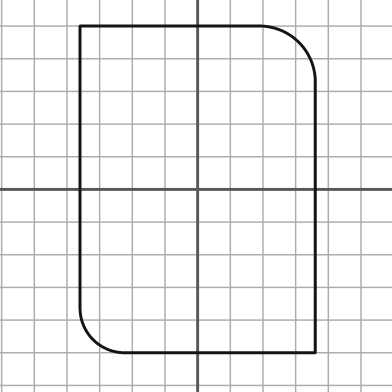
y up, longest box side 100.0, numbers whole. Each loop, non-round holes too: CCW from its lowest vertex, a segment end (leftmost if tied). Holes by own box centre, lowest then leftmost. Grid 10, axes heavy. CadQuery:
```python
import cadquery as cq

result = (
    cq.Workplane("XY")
    .moveTo(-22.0, -50.0)
    .lineTo(36.0, -50.0)
    .lineTo(36.0, 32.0)
    .threePointArc((31.0, 45.0), (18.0, 50.0))
    .lineTo(-36.0, 50.0)
    .lineTo(-36.0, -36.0)
    .threePointArc((-32.0, -46.0), (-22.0, -50.0))
    .close()
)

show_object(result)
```